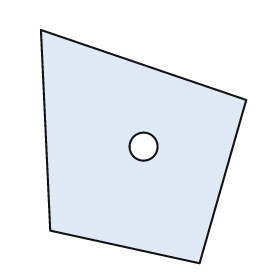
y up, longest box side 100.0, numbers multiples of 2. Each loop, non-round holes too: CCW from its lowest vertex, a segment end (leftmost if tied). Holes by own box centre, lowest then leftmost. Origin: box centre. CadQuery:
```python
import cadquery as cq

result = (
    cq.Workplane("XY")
    .moveTo(24.0, -50.0)
    .lineTo(44.0, 20.0)
    .lineTo(-44.0, 50.0)
    .lineTo(-40.0, -36.0)
    .close()
    .moveTo(0.0, 0.0)
    .circle(6.0)
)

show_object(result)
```